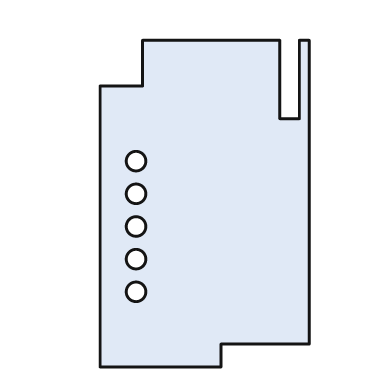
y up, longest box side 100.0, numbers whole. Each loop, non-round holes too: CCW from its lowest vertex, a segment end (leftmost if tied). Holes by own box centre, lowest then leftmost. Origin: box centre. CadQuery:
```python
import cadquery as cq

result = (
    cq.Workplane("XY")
    .moveTo(-32.0, -50.0)
    .lineTo(5.0, -50.0)
    .lineTo(5.0, -43.0)
    .lineTo(32.0, -43.0)
    .lineTo(32.0, 50.0)
    .lineTo(29.0, 50.0)
    .lineTo(29.0, 26.0)
    .lineTo(23.0, 26.0)
    .lineTo(23.0, 50.0)
    .lineTo(-19.0, 50.0)
    .lineTo(-19.0, 36.0)
    .lineTo(-32.0, 36.0)
    .close()
    .moveTo(-21.0, -27.0)
    .circle(3.0)
    .moveTo(-21.0, -17.0)
    .circle(3.0)
    .moveTo(-21.0, -7.0)
    .circle(3.0)
    .moveTo(-21.0, 3.0)
    .circle(3.0)
    .moveTo(-21.0, 13.0)
    .circle(3.0)
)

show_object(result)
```